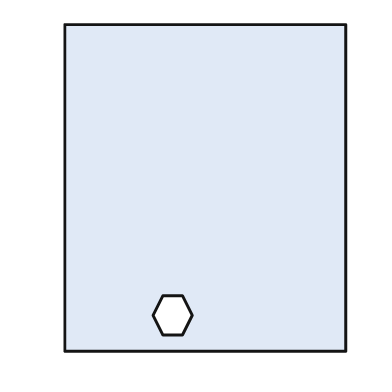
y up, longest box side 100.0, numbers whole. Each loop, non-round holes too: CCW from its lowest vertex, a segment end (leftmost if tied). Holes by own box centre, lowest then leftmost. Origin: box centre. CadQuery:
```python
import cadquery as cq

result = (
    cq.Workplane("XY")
    .moveTo(-43.0, -50.0)
    .lineTo(43.0, -50.0)
    .lineTo(43.0, 50.0)
    .lineTo(-43.0, 50.0)
    .close()
    .moveTo(-13.0, -45.0)
    .lineTo(-7.0, -45.0)
    .lineTo(-4.0, -39.0)
    .lineTo(-7.0, -33.0)
    .lineTo(-13.0, -33.0)
    .lineTo(-16.0, -39.0)
    .close()
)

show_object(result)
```